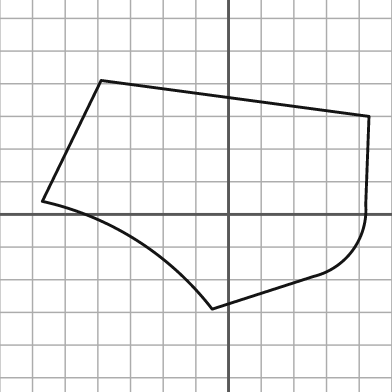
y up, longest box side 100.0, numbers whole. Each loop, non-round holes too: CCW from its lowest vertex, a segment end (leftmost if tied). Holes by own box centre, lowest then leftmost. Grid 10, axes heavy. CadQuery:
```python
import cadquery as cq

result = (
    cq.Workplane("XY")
    .moveTo(-5.0, -29.0)
    .lineTo(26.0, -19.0)
    .threePointArc((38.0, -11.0), (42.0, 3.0))
    .lineTo(43.0, 30.0)
    .lineTo(-39.0, 41.0)
    .lineTo(-57.0, 4.0)
    .threePointArc((-28.0, -8.0), (-5.0, -29.0))
    .close()
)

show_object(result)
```